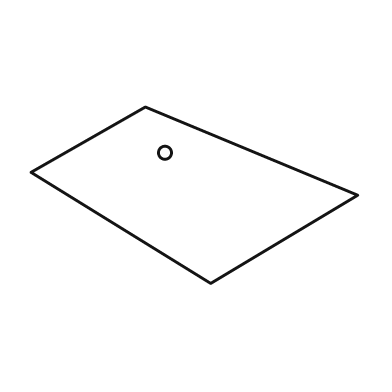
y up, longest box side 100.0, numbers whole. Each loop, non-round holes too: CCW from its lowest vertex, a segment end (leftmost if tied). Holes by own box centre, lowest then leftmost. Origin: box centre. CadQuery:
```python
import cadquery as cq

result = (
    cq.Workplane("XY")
    .moveTo(5.0, -27.0)
    .lineTo(50.0, 0.0)
    .lineTo(-15.0, 27.0)
    .lineTo(-50.0, 7.0)
    .close()
    .moveTo(-9.0, 13.0)
    .circle(2.0)
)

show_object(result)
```